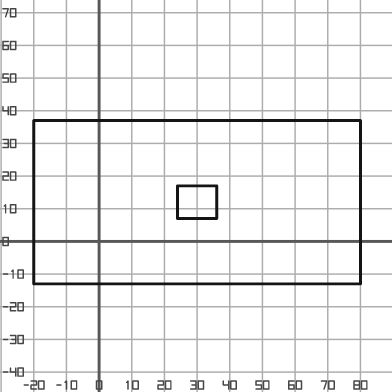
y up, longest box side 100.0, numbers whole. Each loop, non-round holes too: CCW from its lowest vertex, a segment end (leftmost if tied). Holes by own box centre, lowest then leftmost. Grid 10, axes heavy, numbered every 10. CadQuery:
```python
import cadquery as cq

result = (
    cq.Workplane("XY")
    .moveTo(-20.0, -13.0)
    .lineTo(80.0, -13.0)
    .lineTo(80.0, 37.0)
    .lineTo(-20.0, 37.0)
    .close()
    .moveTo(24.0, 7.0)
    .lineTo(36.0, 7.0)
    .lineTo(36.0, 17.0)
    .lineTo(24.0, 17.0)
    .close()
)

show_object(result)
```